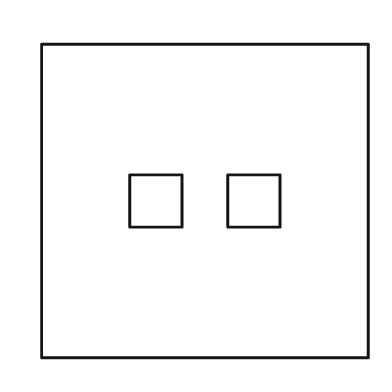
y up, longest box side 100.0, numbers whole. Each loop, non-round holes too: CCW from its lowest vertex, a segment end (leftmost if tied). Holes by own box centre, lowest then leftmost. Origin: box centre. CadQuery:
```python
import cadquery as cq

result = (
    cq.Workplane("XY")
    .moveTo(-50.0, -48.0)
    .lineTo(50.0, -48.0)
    .lineTo(50.0, 48.0)
    .lineTo(-50.0, 48.0)
    .close()
    .moveTo(-23.0, -8.0)
    .lineTo(-7.0, -8.0)
    .lineTo(-7.0, 8.0)
    .lineTo(-23.0, 8.0)
    .close()
    .moveTo(7.0, -8.0)
    .lineTo(23.0, -8.0)
    .lineTo(23.0, 8.0)
    .lineTo(7.0, 8.0)
    .close()
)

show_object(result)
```